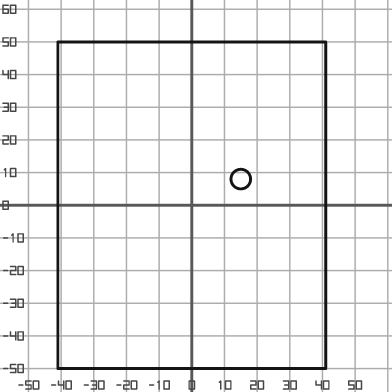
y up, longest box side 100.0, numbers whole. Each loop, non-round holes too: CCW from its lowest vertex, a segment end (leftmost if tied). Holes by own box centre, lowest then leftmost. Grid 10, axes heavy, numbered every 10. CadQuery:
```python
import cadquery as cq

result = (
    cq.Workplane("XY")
    .moveTo(-41.0, -50.0)
    .lineTo(41.0, -50.0)
    .lineTo(41.0, 50.0)
    .lineTo(-41.0, 50.0)
    .close()
    .moveTo(15.0, 8.0)
    .circle(3.0)
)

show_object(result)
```